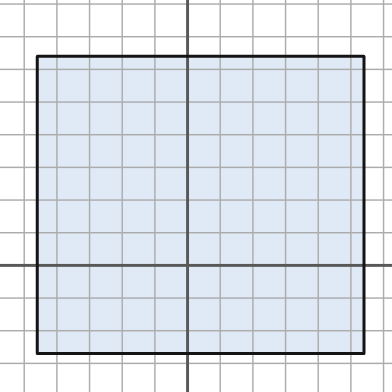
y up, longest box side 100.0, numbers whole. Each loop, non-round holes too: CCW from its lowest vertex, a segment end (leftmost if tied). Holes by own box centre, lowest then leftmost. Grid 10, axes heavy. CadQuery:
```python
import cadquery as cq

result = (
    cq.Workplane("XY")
    .moveTo(-46.0, -27.0)
    .lineTo(54.0, -27.0)
    .lineTo(54.0, 64.0)
    .lineTo(-46.0, 64.0)
    .close()
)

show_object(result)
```